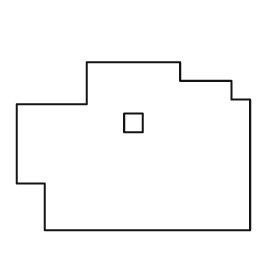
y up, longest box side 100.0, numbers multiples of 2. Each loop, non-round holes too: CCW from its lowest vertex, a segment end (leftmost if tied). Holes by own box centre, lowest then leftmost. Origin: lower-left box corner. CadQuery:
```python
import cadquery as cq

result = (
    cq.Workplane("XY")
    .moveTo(12.0, 0.0)
    .lineTo(100.0, 0.0)
    .lineTo(100.0, 56.0)
    .lineTo(92.0, 56.0)
    .lineTo(92.0, 64.0)
    .lineTo(70.0, 64.0)
    .lineTo(70.0, 72.0)
    .lineTo(30.0, 72.0)
    .lineTo(30.0, 54.0)
    .lineTo(0.0, 54.0)
    .lineTo(0.0, 20.0)
    .lineTo(12.0, 20.0)
    .close()
    .moveTo(46.0, 42.0)
    .lineTo(54.0, 42.0)
    .lineTo(54.0, 50.0)
    .lineTo(46.0, 50.0)
    .close()
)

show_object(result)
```